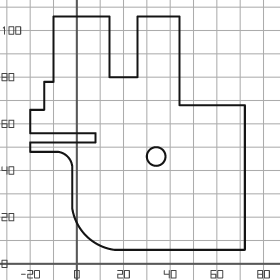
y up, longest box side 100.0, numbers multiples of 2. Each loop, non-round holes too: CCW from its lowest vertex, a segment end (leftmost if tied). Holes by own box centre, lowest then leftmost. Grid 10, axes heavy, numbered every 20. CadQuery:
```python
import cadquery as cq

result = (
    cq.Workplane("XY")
    .moveTo(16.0, 6.0)
    .lineTo(72.0, 6.0)
    .lineTo(72.0, 68.0)
    .lineTo(44.0, 68.0)
    .lineTo(44.0, 106.0)
    .lineTo(26.0, 106.0)
    .lineTo(26.0, 80.0)
    .lineTo(14.0, 80.0)
    .lineTo(14.0, 106.0)
    .lineTo(-10.0, 106.0)
    .lineTo(-10.0, 78.0)
    .lineTo(-14.0, 78.0)
    .lineTo(-14.0, 66.0)
    .lineTo(-20.0, 66.0)
    .lineTo(-20.0, 56.0)
    .lineTo(8.0, 56.0)
    .lineTo(8.0, 52.0)
    .lineTo(-20.0, 52.0)
    .lineTo(-20.0, 48.0)
    .lineTo(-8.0, 48.0)
    .threePointArc((-4.0, 46.0), (-2.0, 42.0))
    .lineTo(-2.0, 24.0)
    .threePointArc((4.0, 12.0), (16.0, 6.0))
    .close()
    .moveTo(34.0, 46.0)
    .circle(4.0)
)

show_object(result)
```